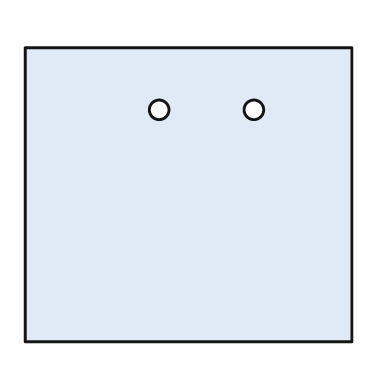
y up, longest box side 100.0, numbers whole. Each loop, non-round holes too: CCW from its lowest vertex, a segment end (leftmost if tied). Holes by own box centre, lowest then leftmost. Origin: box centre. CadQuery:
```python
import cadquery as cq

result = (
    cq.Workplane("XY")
    .moveTo(-50.0, -45.0)
    .lineTo(50.0, -45.0)
    .lineTo(50.0, 45.0)
    .lineTo(-50.0, 45.0)
    .close()
    .moveTo(-9.0, 26.0)
    .circle(3.0)
    .moveTo(20.0, 26.0)
    .circle(3.0)
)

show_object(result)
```